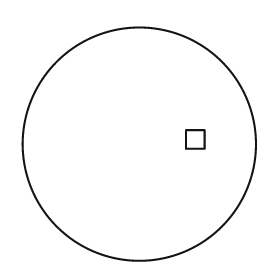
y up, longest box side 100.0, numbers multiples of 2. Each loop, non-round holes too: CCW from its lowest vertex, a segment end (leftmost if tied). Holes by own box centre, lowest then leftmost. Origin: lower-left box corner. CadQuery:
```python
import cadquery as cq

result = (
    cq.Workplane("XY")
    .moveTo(50.0, 50.0)
    .circle(50.0)
    .moveTo(70.0, 48.0)
    .lineTo(78.0, 48.0)
    .lineTo(78.0, 56.0)
    .lineTo(70.0, 56.0)
    .close()
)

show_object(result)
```